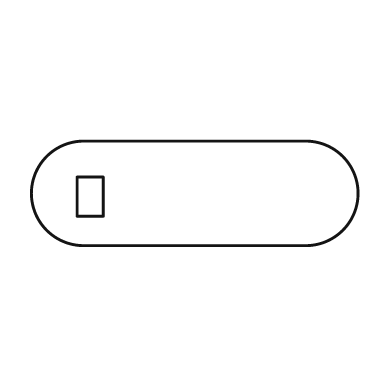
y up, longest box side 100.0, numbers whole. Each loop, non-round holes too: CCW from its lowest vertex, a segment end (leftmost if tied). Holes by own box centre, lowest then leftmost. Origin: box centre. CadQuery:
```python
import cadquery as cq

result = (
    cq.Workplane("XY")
    .moveTo(-34.0, -16.0)
    .lineTo(34.0, -16.0)
    .threePointArc((50.0, 0.0), (34.0, 16.0))
    .lineTo(-34.0, 16.0)
    .threePointArc((-50.0, 0.0), (-34.0, -16.0))
    .close()
    .moveTo(-36.0, -7.0)
    .lineTo(-28.0, -7.0)
    .lineTo(-28.0, 5.0)
    .lineTo(-36.0, 5.0)
    .close()
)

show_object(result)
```